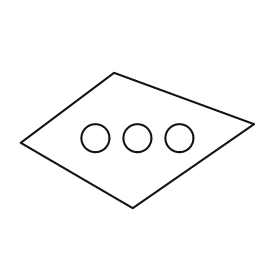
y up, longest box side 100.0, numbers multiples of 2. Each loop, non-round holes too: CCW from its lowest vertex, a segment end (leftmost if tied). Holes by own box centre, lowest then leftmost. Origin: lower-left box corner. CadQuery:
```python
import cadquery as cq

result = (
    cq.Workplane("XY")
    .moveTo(48.0, 0.0)
    .lineTo(100.0, 36.0)
    .lineTo(40.0, 58.0)
    .lineTo(0.0, 28.0)
    .close()
    .moveTo(32.0, 30.0)
    .circle(6.0)
    .moveTo(50.0, 30.0)
    .circle(6.0)
    .moveTo(68.0, 30.0)
    .circle(6.0)
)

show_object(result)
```